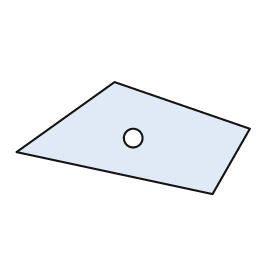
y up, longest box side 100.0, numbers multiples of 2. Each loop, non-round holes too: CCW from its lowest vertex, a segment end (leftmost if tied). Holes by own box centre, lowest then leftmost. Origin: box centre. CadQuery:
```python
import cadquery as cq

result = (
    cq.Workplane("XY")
    .moveTo(34.0, -24.0)
    .lineTo(50.0, 4.0)
    .lineTo(-8.0, 24.0)
    .lineTo(-50.0, -6.0)
    .close()
    .moveTo(0.0, 0.0)
    .circle(4.0)
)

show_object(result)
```